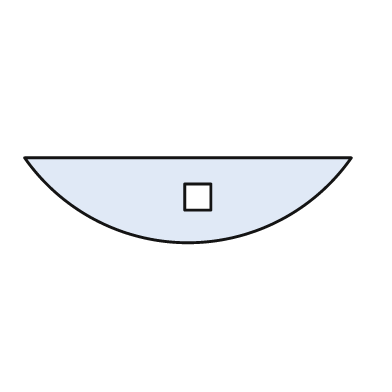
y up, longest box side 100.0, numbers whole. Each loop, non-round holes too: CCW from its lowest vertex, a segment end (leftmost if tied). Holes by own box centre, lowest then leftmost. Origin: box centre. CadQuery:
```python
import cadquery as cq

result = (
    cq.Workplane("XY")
    .moveTo(-50.0, 13.0)
    .threePointArc((0.0, -13.0), (50.0, 13.0))
    .close()
    .moveTo(-1.0, -3.0)
    .lineTo(7.0, -3.0)
    .lineTo(7.0, 5.0)
    .lineTo(-1.0, 5.0)
    .close()
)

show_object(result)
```